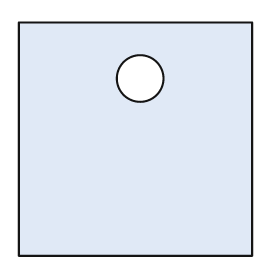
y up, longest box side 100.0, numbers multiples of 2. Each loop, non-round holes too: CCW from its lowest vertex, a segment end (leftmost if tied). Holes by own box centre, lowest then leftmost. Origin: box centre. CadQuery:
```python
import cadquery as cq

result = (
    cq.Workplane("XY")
    .moveTo(-50.0, -50.0)
    .lineTo(50.0, -50.0)
    .lineTo(50.0, 50.0)
    .lineTo(-50.0, 50.0)
    .close()
    .moveTo(2.0, 26.0)
    .circle(10.0)
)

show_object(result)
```